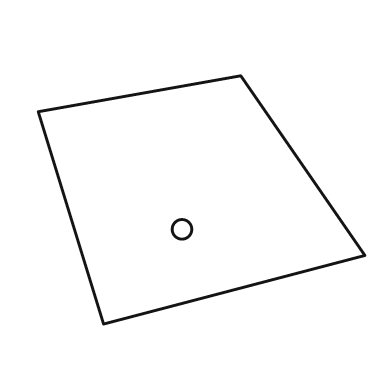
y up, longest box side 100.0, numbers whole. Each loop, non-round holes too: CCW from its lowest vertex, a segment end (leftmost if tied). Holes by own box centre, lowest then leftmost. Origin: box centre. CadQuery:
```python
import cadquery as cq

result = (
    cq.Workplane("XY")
    .moveTo(-30.0, -38.0)
    .lineTo(50.0, -17.0)
    .lineTo(12.0, 38.0)
    .lineTo(-50.0, 27.0)
    .close()
    .moveTo(-6.0, -9.0)
    .circle(3.0)
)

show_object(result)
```